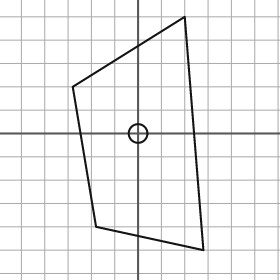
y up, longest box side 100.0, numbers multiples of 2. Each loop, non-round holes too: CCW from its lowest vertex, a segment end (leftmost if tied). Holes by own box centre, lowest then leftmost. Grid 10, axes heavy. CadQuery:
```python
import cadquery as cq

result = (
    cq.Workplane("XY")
    .moveTo(28.0, -50.0)
    .lineTo(20.0, 50.0)
    .lineTo(-28.0, 20.0)
    .lineTo(-18.0, -40.0)
    .close()
    .moveTo(0.0, 0.0)
    .circle(4.0)
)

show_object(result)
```